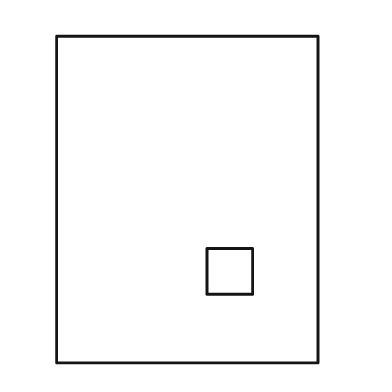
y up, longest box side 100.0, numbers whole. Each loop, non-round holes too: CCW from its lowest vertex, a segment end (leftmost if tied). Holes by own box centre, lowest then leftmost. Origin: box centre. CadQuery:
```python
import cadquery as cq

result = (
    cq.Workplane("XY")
    .moveTo(-40.0, -50.0)
    .lineTo(40.0, -50.0)
    .lineTo(40.0, 50.0)
    .lineTo(-40.0, 50.0)
    .close()
    .moveTo(6.0, -29.0)
    .lineTo(20.0, -29.0)
    .lineTo(20.0, -15.0)
    .lineTo(6.0, -15.0)
    .close()
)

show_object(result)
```